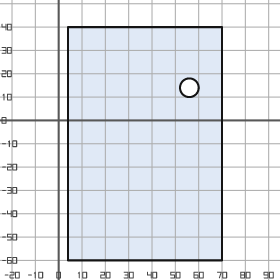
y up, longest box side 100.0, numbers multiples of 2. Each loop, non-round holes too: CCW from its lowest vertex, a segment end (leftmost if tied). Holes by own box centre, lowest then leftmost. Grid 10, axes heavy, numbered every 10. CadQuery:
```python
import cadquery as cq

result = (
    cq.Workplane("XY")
    .moveTo(4.0, -60.0)
    .lineTo(70.0, -60.0)
    .lineTo(70.0, 40.0)
    .lineTo(4.0, 40.0)
    .close()
    .moveTo(56.0, 14.0)
    .circle(4.0)
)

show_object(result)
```